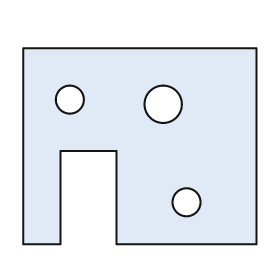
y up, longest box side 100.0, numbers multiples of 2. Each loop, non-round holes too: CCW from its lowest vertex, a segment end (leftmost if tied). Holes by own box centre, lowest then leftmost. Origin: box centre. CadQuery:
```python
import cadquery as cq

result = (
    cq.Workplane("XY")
    .moveTo(-50.0, -42.0)
    .lineTo(-34.0, -42.0)
    .lineTo(-34.0, -2.0)
    .lineTo(-10.0, -2.0)
    .lineTo(-10.0, -42.0)
    .lineTo(50.0, -42.0)
    .lineTo(50.0, 42.0)
    .lineTo(-50.0, 42.0)
    .close()
    .moveTo(20.0, -24.0)
    .circle(6.0)
    .moveTo(10.0, 18.0)
    .circle(8.0)
    .moveTo(-30.0, 20.0)
    .circle(6.0)
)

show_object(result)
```